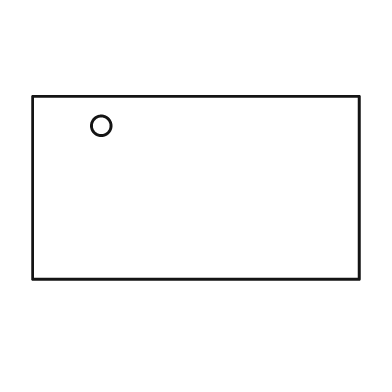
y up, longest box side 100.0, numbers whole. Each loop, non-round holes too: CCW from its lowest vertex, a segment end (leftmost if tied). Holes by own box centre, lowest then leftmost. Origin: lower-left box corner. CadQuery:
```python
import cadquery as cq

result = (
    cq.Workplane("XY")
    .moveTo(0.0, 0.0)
    .lineTo(100.0, 0.0)
    .lineTo(100.0, 56.0)
    .lineTo(0.0, 56.0)
    .close()
    .moveTo(21.0, 47.0)
    .circle(3.0)
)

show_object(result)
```